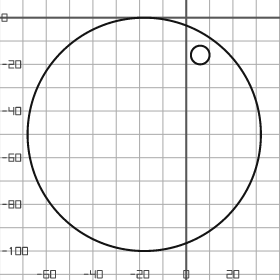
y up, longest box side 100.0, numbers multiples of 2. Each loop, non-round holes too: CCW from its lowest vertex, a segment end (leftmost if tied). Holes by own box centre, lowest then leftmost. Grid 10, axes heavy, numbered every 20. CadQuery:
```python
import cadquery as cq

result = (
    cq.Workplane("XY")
    .moveTo(-18.0, -50.0)
    .circle(50.0)
    .moveTo(6.0, -16.0)
    .circle(4.0)
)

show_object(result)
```